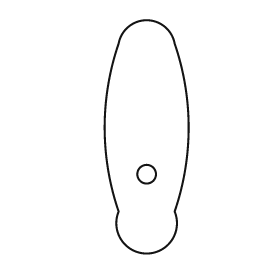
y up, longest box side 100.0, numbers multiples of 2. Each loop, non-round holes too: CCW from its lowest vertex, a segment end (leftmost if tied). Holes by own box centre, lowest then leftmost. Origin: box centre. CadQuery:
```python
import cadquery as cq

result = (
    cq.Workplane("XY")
    .moveTo(-12.0, -32.0)
    .threePointArc((0.0, -50.0), (12.0, -32.0))
    .threePointArc((18.0, 4.0), (12.0, 40.0))
    .threePointArc((0.0, 50.0), (-12.0, 40.0))
    .threePointArc((-18.0, 4.0), (-12.0, -32.0))
    .close()
    .moveTo(0.0, -16.0)
    .circle(4.0)
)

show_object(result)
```